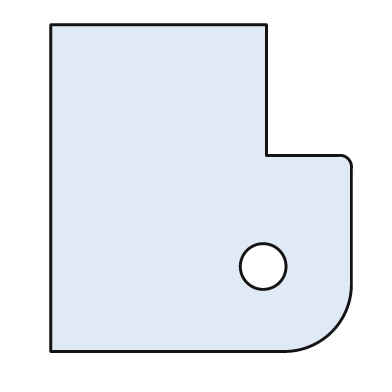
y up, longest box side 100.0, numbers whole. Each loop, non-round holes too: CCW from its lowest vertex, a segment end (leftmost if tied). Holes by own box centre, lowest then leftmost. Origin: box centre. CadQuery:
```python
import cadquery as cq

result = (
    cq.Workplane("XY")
    .moveTo(-46.0, -50.0)
    .lineTo(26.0, -50.0)
    .threePointArc((40.0, -44.0), (46.0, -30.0))
    .lineTo(46.0, 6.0)
    .threePointArc((45.0, 9.0), (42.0, 10.0))
    .lineTo(20.0, 10.0)
    .lineTo(20.0, 50.0)
    .lineTo(-46.0, 50.0)
    .close()
    .moveTo(19.0, -24.0)
    .circle(7.0)
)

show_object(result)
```